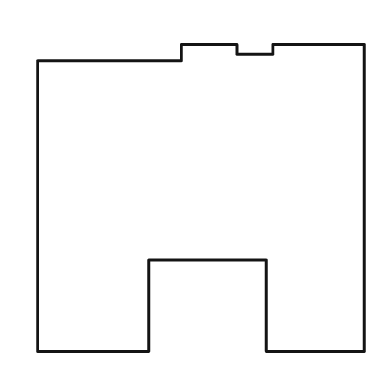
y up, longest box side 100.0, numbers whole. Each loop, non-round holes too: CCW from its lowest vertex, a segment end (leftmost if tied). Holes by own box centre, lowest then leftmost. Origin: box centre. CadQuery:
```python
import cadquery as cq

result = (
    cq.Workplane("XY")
    .moveTo(-50.0, -47.0)
    .lineTo(-16.0, -47.0)
    .lineTo(-16.0, -19.0)
    .lineTo(20.0, -19.0)
    .lineTo(20.0, -47.0)
    .lineTo(50.0, -47.0)
    .lineTo(50.0, 47.0)
    .lineTo(22.0, 47.0)
    .lineTo(22.0, 44.0)
    .lineTo(11.0, 44.0)
    .lineTo(11.0, 47.0)
    .lineTo(-6.0, 47.0)
    .lineTo(-6.0, 42.0)
    .lineTo(-50.0, 42.0)
    .close()
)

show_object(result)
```